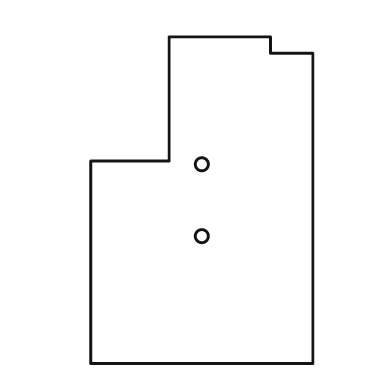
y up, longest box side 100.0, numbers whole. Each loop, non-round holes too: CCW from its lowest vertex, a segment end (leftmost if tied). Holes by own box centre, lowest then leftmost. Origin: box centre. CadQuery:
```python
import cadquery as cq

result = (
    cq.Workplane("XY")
    .moveTo(-34.0, -50.0)
    .lineTo(34.0, -50.0)
    .lineTo(34.0, 45.0)
    .lineTo(21.0, 45.0)
    .lineTo(21.0, 50.0)
    .lineTo(-10.0, 50.0)
    .lineTo(-10.0, 12.0)
    .lineTo(-34.0, 12.0)
    .close()
    .moveTo(0.0, -11.0)
    .circle(2.0)
    .moveTo(0.0, 11.0)
    .circle(2.0)
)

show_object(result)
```